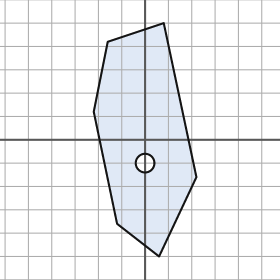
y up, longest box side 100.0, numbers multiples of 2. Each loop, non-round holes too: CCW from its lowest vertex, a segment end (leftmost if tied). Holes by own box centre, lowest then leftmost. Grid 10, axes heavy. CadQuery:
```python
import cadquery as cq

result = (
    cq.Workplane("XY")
    .moveTo(6.0, -50.0)
    .lineTo(22.0, -16.0)
    .lineTo(8.0, 50.0)
    .lineTo(-16.0, 42.0)
    .lineTo(-22.0, 12.0)
    .lineTo(-12.0, -36.0)
    .close()
    .moveTo(0.0, -10.0)
    .circle(4.0)
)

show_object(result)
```